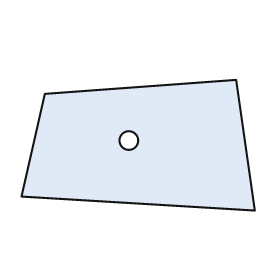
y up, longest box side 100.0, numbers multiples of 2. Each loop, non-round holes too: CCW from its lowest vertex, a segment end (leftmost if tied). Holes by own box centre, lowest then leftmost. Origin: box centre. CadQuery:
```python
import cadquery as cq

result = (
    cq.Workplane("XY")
    .moveTo(50.0, -28.0)
    .lineTo(42.0, 28.0)
    .lineTo(-40.0, 22.0)
    .lineTo(-50.0, -22.0)
    .close()
    .moveTo(-4.0, 2.0)
    .circle(4.0)
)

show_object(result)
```